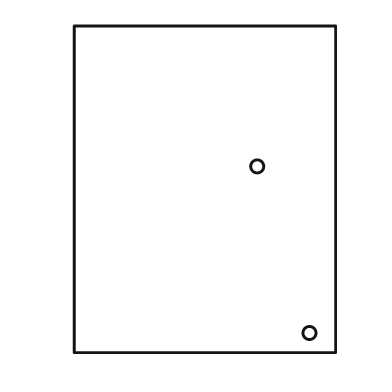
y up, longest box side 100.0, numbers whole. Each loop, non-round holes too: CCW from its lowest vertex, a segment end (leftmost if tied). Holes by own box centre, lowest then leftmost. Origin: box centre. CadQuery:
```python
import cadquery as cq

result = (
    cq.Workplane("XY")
    .moveTo(-40.0, -50.0)
    .lineTo(40.0, -50.0)
    .lineTo(40.0, 50.0)
    .lineTo(-40.0, 50.0)
    .close()
    .moveTo(32.0, -44.0)
    .circle(2.0)
    .moveTo(16.0, 7.0)
    .circle(2.0)
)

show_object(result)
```